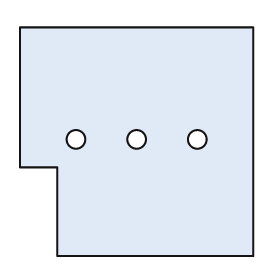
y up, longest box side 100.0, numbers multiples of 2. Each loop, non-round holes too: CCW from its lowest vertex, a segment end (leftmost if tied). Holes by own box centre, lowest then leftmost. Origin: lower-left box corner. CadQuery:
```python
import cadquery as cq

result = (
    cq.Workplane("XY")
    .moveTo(16.0, 0.0)
    .lineTo(100.0, 0.0)
    .lineTo(100.0, 98.0)
    .lineTo(0.0, 98.0)
    .lineTo(0.0, 38.0)
    .lineTo(16.0, 38.0)
    .close()
    .moveTo(24.0, 50.0)
    .circle(4.0)
    .moveTo(50.0, 50.0)
    .circle(4.0)
    .moveTo(76.0, 50.0)
    .circle(4.0)
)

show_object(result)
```